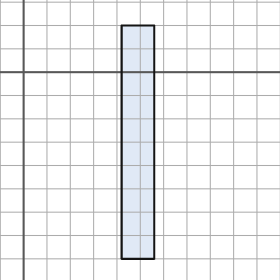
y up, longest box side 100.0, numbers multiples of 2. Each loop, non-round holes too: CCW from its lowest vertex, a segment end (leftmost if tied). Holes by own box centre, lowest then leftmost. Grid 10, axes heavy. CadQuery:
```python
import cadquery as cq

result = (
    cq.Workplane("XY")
    .moveTo(42.0, -80.0)
    .lineTo(56.0, -80.0)
    .lineTo(56.0, 20.0)
    .lineTo(42.0, 20.0)
    .close()
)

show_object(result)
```